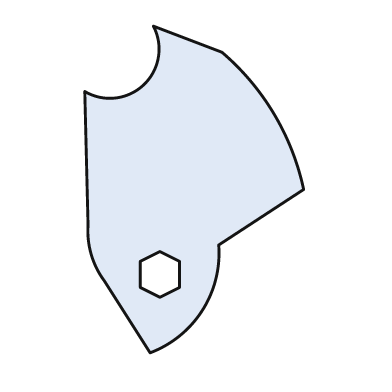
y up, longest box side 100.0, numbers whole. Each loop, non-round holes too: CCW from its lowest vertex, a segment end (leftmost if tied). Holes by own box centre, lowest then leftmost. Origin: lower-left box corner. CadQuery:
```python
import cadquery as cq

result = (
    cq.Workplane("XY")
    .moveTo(20.0, 0.0)
    .threePointArc((36.0, 13.0), (41.0, 33.0))
    .lineTo(67.0, 50.0)
    .threePointArc((58.0, 73.0), (42.0, 92.0))
    .lineTo(21.0, 100.0)
    .threePointArc((18.0, 82.0), (0.0, 80.0))
    .lineTo(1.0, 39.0)
    .threePointArc((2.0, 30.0), (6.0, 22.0))
    .close()
    .moveTo(23.0, 17.0)
    .lineTo(29.0, 20.0)
    .lineTo(29.0, 28.0)
    .lineTo(23.0, 31.0)
    .lineTo(17.0, 28.0)
    .lineTo(17.0, 20.0)
    .close()
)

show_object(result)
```